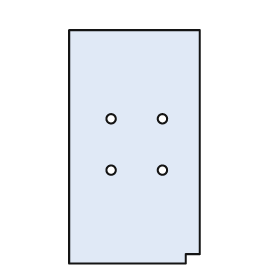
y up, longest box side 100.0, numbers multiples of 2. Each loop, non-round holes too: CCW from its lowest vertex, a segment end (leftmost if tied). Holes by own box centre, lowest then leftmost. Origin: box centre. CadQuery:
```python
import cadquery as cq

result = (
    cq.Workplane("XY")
    .moveTo(-28.0, -50.0)
    .lineTo(22.0, -50.0)
    .lineTo(22.0, -46.0)
    .lineTo(28.0, -46.0)
    .lineTo(28.0, 50.0)
    .lineTo(-28.0, 50.0)
    .close()
    .moveTo(-10.0, -10.0)
    .circle(2.0)
    .moveTo(12.0, -10.0)
    .circle(2.0)
    .moveTo(-10.0, 12.0)
    .circle(2.0)
    .moveTo(12.0, 12.0)
    .circle(2.0)
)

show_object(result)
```